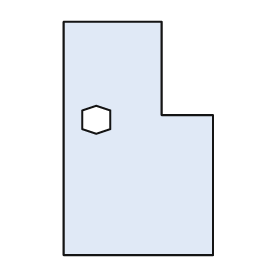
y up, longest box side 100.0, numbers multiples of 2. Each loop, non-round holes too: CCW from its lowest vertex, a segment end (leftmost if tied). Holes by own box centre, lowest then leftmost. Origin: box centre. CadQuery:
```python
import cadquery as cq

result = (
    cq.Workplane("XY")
    .moveTo(-32.0, -50.0)
    .lineTo(32.0, -50.0)
    .lineTo(32.0, 10.0)
    .lineTo(10.0, 10.0)
    .lineTo(10.0, 50.0)
    .lineTo(-32.0, 50.0)
    .close()
    .moveTo(-18.0, 2.0)
    .lineTo(-12.0, 4.0)
    .lineTo(-12.0, 12.0)
    .lineTo(-18.0, 14.0)
    .lineTo(-24.0, 12.0)
    .lineTo(-24.0, 4.0)
    .close()
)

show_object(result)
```